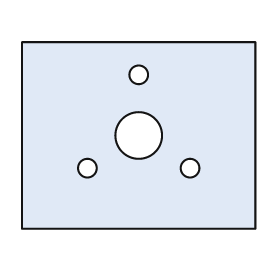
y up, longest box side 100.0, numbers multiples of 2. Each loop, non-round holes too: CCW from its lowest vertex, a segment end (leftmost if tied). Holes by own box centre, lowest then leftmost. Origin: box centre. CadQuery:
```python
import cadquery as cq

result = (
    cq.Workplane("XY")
    .moveTo(-50.0, -40.0)
    .lineTo(50.0, -40.0)
    .lineTo(50.0, 40.0)
    .lineTo(-50.0, 40.0)
    .close()
    .moveTo(-22.0, -14.0)
    .circle(4.0)
    .moveTo(22.0, -14.0)
    .circle(4.0)
    .moveTo(0.0, 0.0)
    .circle(10.0)
    .moveTo(0.0, 26.0)
    .circle(4.0)
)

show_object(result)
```